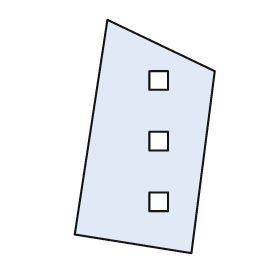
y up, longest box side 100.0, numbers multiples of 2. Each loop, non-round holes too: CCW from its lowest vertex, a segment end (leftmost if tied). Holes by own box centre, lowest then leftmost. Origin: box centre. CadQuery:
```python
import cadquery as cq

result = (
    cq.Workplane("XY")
    .moveTo(20.0, -50.0)
    .lineTo(30.0, 28.0)
    .lineTo(-16.0, 50.0)
    .lineTo(-30.0, -42.0)
    .close()
    .moveTo(2.0, -32.0)
    .lineTo(10.0, -32.0)
    .lineTo(10.0, -24.0)
    .lineTo(2.0, -24.0)
    .close()
    .moveTo(2.0, -6.0)
    .lineTo(10.0, -6.0)
    .lineTo(10.0, 2.0)
    .lineTo(2.0, 2.0)
    .close()
    .moveTo(2.0, 20.0)
    .lineTo(10.0, 20.0)
    .lineTo(10.0, 28.0)
    .lineTo(2.0, 28.0)
    .close()
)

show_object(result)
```